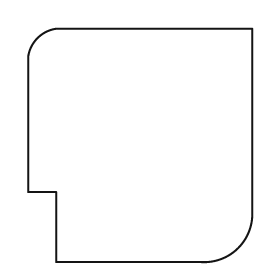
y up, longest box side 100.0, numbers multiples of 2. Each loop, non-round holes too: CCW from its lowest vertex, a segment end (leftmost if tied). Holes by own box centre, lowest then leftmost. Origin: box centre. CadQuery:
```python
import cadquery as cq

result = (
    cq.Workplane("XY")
    .moveTo(-36.0, -50.0)
    .lineTo(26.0, -50.0)
    .threePointArc((42.0, -44.0), (48.0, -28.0))
    .lineTo(48.0, 50.0)
    .lineTo(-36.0, 50.0)
    .threePointArc((-44.0, 46.0), (-48.0, 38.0))
    .lineTo(-48.0, -20.0)
    .lineTo(-36.0, -20.0)
    .close()
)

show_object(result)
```